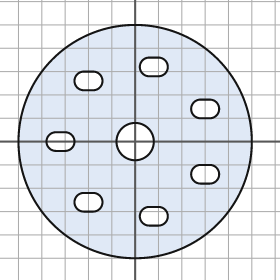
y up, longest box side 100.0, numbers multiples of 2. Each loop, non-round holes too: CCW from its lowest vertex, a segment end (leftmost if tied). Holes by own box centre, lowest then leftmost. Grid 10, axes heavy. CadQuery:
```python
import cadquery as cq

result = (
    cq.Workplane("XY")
    .moveTo(0.0, 0.0)
    .circle(50.0)
    .moveTo(6.0, -36.0)
    .lineTo(10.0, -36.0)
    .threePointArc((14.0, -32.0), (10.0, -28.0))
    .lineTo(6.0, -28.0)
    .threePointArc((2.0, -32.0), (6.0, -36.0))
    .close()
    .moveTo(-22.0, -30.0)
    .lineTo(-18.0, -30.0)
    .threePointArc((-14.0, -26.0), (-18.0, -22.0))
    .lineTo(-22.0, -22.0)
    .threePointArc((-26.0, -26.0), (-22.0, -30.0))
    .close()
    .moveTo(28.0, -18.0)
    .lineTo(32.0, -18.0)
    .threePointArc((36.0, -14.0), (32.0, -10.0))
    .lineTo(28.0, -10.0)
    .threePointArc((24.0, -14.0), (28.0, -18.0))
    .close()
    .moveTo(-34.0, -4.0)
    .lineTo(-30.0, -4.0)
    .threePointArc((-26.0, 0.0), (-30.0, 4.0))
    .lineTo(-34.0, 4.0)
    .threePointArc((-38.0, 0.0), (-34.0, -4.0))
    .close()
    .moveTo(0.0, 0.0)
    .circle(8.0)
    .moveTo(28.0, 10.0)
    .lineTo(32.0, 10.0)
    .threePointArc((36.0, 14.0), (32.0, 18.0))
    .lineTo(28.0, 18.0)
    .threePointArc((24.0, 14.0), (28.0, 10.0))
    .close()
    .moveTo(-22.0, 22.0)
    .lineTo(-18.0, 22.0)
    .threePointArc((-14.0, 26.0), (-18.0, 30.0))
    .lineTo(-22.0, 30.0)
    .threePointArc((-26.0, 26.0), (-22.0, 22.0))
    .close()
    .moveTo(6.0, 28.0)
    .lineTo(10.0, 28.0)
    .threePointArc((14.0, 32.0), (10.0, 36.0))
    .lineTo(6.0, 36.0)
    .threePointArc((2.0, 32.0), (6.0, 28.0))
    .close()
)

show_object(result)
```